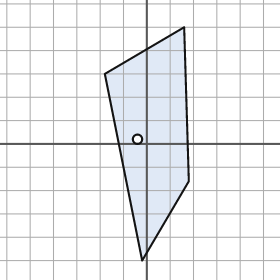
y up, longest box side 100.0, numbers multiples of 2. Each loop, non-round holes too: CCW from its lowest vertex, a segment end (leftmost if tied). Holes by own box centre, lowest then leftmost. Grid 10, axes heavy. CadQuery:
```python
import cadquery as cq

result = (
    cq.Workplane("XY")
    .moveTo(-2.0, -50.0)
    .lineTo(18.0, -16.0)
    .lineTo(16.0, 50.0)
    .lineTo(-18.0, 30.0)
    .close()
    .moveTo(-4.0, 2.0)
    .circle(2.0)
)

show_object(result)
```